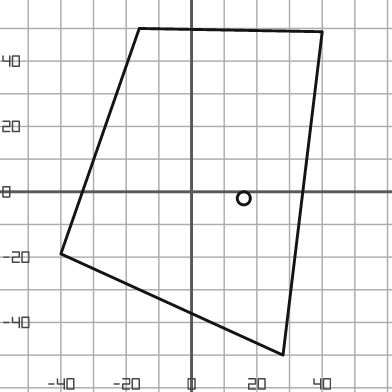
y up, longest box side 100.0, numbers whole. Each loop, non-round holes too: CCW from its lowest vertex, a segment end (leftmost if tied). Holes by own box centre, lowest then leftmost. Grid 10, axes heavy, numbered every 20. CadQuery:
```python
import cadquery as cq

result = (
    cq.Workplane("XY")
    .moveTo(28.0, -50.0)
    .lineTo(40.0, 49.0)
    .lineTo(-16.0, 50.0)
    .lineTo(-40.0, -19.0)
    .close()
    .moveTo(16.0, -2.0)
    .circle(2.0)
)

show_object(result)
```